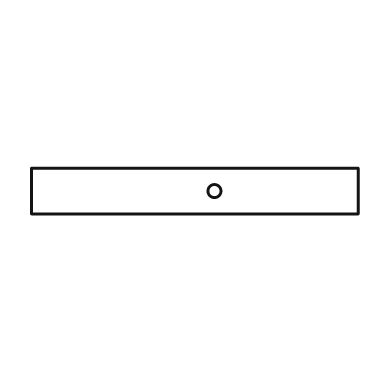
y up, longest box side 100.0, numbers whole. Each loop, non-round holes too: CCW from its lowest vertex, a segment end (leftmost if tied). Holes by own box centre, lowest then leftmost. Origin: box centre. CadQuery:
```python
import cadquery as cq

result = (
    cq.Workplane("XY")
    .moveTo(-50.0, -7.0)
    .lineTo(50.0, -7.0)
    .lineTo(50.0, 7.0)
    .lineTo(-50.0, 7.0)
    .close()
    .moveTo(6.0, 0.0)
    .circle(2.0)
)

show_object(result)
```